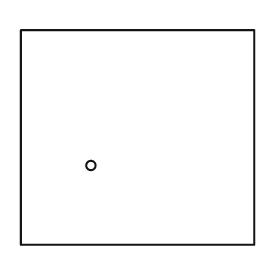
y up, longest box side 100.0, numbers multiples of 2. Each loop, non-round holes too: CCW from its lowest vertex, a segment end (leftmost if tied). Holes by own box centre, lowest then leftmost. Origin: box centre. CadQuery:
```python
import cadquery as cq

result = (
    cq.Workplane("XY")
    .moveTo(-50.0, -46.0)
    .lineTo(50.0, -46.0)
    .lineTo(50.0, 46.0)
    .lineTo(-50.0, 46.0)
    .close()
    .moveTo(-20.0, -12.0)
    .circle(2.0)
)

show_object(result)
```